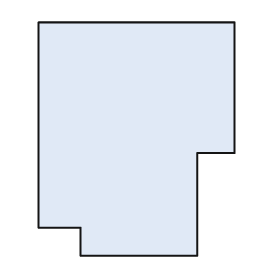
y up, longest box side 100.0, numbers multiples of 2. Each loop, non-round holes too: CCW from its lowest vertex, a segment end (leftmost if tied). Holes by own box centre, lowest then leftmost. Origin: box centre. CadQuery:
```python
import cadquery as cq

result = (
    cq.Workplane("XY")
    .moveTo(-24.0, -50.0)
    .lineTo(26.0, -50.0)
    .lineTo(26.0, -6.0)
    .lineTo(42.0, -6.0)
    .lineTo(42.0, 50.0)
    .lineTo(-42.0, 50.0)
    .lineTo(-42.0, -38.0)
    .lineTo(-24.0, -38.0)
    .close()
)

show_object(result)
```